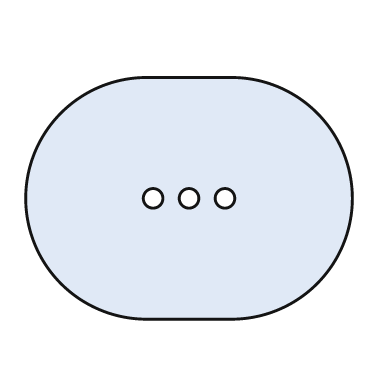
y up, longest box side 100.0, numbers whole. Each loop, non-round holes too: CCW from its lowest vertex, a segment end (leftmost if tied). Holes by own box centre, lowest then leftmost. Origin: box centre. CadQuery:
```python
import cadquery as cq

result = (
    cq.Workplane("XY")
    .moveTo(-13.0, -37.0)
    .lineTo(13.0, -37.0)
    .threePointArc((50.0, 0.0), (13.0, 37.0))
    .lineTo(-13.0, 37.0)
    .threePointArc((-50.0, 0.0), (-13.0, -37.0))
    .close()
    .moveTo(-11.0, 0.0)
    .circle(3.0)
    .moveTo(0.0, 0.0)
    .circle(3.0)
    .moveTo(11.0, 0.0)
    .circle(3.0)
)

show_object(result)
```